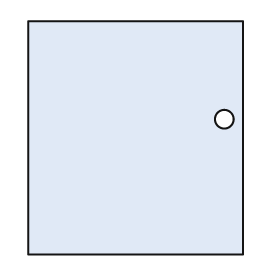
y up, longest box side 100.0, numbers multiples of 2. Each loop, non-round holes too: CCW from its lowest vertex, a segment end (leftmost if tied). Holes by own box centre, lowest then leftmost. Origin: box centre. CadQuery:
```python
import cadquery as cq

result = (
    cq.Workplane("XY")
    .moveTo(-46.0, -50.0)
    .lineTo(46.0, -50.0)
    .lineTo(46.0, 50.0)
    .lineTo(-46.0, 50.0)
    .close()
    .moveTo(38.0, 8.0)
    .circle(4.0)
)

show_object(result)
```